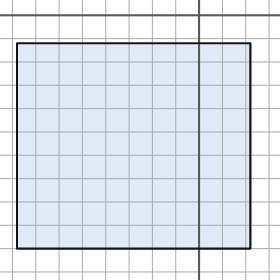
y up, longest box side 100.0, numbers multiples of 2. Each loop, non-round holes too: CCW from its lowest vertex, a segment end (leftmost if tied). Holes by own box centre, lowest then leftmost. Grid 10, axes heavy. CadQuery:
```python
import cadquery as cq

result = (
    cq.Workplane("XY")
    .moveTo(-78.0, -100.0)
    .lineTo(22.0, -100.0)
    .lineTo(22.0, -12.0)
    .lineTo(-78.0, -12.0)
    .close()
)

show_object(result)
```